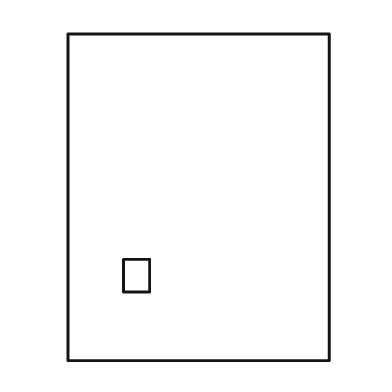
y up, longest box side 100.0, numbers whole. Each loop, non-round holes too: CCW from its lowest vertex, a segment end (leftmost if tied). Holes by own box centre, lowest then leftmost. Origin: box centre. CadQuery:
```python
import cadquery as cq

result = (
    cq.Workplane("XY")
    .moveTo(-40.0, -50.0)
    .lineTo(40.0, -50.0)
    .lineTo(40.0, 50.0)
    .lineTo(-40.0, 50.0)
    .close()
    .moveTo(-23.0, -29.0)
    .lineTo(-15.0, -29.0)
    .lineTo(-15.0, -19.0)
    .lineTo(-23.0, -19.0)
    .close()
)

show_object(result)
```